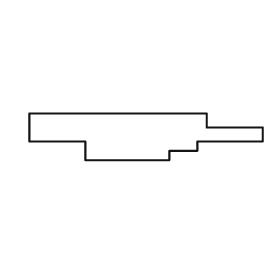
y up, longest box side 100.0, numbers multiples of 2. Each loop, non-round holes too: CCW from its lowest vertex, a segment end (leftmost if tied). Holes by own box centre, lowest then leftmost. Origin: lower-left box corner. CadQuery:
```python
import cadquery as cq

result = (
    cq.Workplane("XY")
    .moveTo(24.0, 0.0)
    .lineTo(60.0, 0.0)
    .lineTo(60.0, 4.0)
    .lineTo(72.0, 4.0)
    .lineTo(72.0, 8.0)
    .lineTo(100.0, 8.0)
    .lineTo(100.0, 14.0)
    .lineTo(76.0, 14.0)
    .lineTo(76.0, 20.0)
    .lineTo(0.0, 20.0)
    .lineTo(0.0, 8.0)
    .lineTo(24.0, 8.0)
    .close()
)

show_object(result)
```